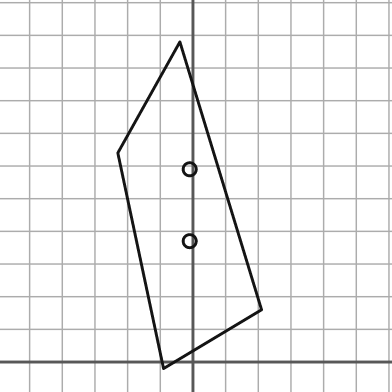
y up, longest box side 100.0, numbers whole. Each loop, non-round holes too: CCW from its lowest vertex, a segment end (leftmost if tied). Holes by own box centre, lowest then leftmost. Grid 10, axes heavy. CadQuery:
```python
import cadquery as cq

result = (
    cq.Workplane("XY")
    .moveTo(-9.0, -2.0)
    .lineTo(21.0, 16.0)
    .lineTo(-4.0, 98.0)
    .lineTo(-23.0, 64.0)
    .close()
    .moveTo(-1.0, 37.0)
    .circle(2.0)
    .moveTo(-1.0, 59.0)
    .circle(2.0)
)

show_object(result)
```